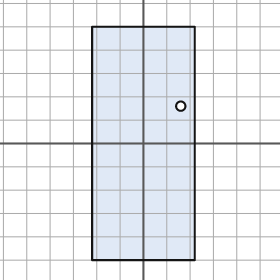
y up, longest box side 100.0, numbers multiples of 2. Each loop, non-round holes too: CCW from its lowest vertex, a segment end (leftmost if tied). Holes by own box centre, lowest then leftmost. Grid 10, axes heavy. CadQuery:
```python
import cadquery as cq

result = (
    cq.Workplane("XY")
    .moveTo(-22.0, -50.0)
    .lineTo(22.0, -50.0)
    .lineTo(22.0, 50.0)
    .lineTo(-22.0, 50.0)
    .close()
    .moveTo(16.0, 16.0)
    .circle(2.0)
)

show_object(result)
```